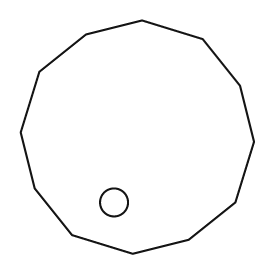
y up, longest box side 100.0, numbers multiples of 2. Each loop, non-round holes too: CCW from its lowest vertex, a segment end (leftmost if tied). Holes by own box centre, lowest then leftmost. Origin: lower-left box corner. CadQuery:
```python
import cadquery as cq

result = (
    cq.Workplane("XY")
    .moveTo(48.0, 0.0)
    .lineTo(72.0, 6.0)
    .lineTo(92.0, 22.0)
    .lineTo(100.0, 48.0)
    .lineTo(94.0, 72.0)
    .lineTo(78.0, 92.0)
    .lineTo(52.0, 100.0)
    .lineTo(28.0, 94.0)
    .lineTo(8.0, 78.0)
    .lineTo(0.0, 52.0)
    .lineTo(6.0, 28.0)
    .lineTo(22.0, 8.0)
    .close()
    .moveTo(40.0, 22.0)
    .circle(6.0)
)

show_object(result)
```